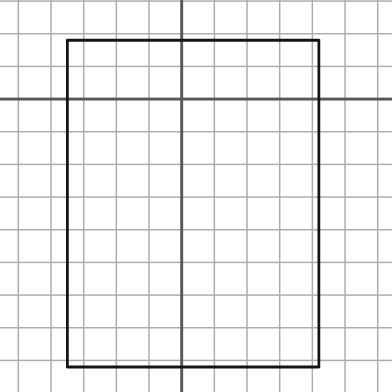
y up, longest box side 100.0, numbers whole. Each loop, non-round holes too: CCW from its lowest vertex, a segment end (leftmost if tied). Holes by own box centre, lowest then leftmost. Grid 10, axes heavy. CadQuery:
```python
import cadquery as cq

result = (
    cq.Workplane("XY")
    .moveTo(-35.0, -82.0)
    .lineTo(42.0, -82.0)
    .lineTo(42.0, 18.0)
    .lineTo(-35.0, 18.0)
    .close()
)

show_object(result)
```